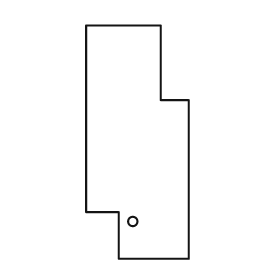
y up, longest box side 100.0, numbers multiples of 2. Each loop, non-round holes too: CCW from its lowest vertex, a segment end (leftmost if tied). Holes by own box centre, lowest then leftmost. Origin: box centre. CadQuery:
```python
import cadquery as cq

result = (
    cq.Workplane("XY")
    .moveTo(-8.0, -50.0)
    .lineTo(22.0, -50.0)
    .lineTo(22.0, 18.0)
    .lineTo(10.0, 18.0)
    .lineTo(10.0, 50.0)
    .lineTo(-22.0, 50.0)
    .lineTo(-22.0, -30.0)
    .lineTo(-8.0, -30.0)
    .close()
    .moveTo(-2.0, -34.0)
    .circle(2.0)
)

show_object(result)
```